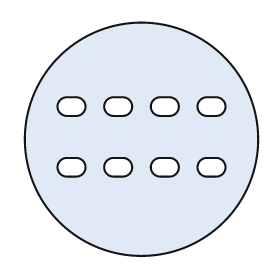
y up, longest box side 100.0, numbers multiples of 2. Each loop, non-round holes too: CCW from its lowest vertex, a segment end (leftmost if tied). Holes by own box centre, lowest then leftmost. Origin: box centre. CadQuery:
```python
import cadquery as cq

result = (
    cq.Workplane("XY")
    .moveTo(0.0, 0.0)
    .circle(50.0)
    .moveTo(-32.0, -16.0)
    .lineTo(-28.0, -16.0)
    .threePointArc((-24.0, -12.0), (-28.0, -8.0))
    .lineTo(-32.0, -8.0)
    .threePointArc((-36.0, -12.0), (-32.0, -16.0))
    .close()
    .moveTo(-12.0, -16.0)
    .lineTo(-8.0, -16.0)
    .threePointArc((-4.0, -12.0), (-8.0, -8.0))
    .lineTo(-12.0, -8.0)
    .threePointArc((-16.0, -12.0), (-12.0, -16.0))
    .close()
    .moveTo(8.0, -16.0)
    .lineTo(12.0, -16.0)
    .threePointArc((16.0, -12.0), (12.0, -8.0))
    .lineTo(8.0, -8.0)
    .threePointArc((4.0, -12.0), (8.0, -16.0))
    .close()
    .moveTo(28.0, -16.0)
    .lineTo(32.0, -16.0)
    .threePointArc((36.0, -12.0), (32.0, -8.0))
    .lineTo(28.0, -8.0)
    .threePointArc((24.0, -12.0), (28.0, -16.0))
    .close()
    .moveTo(-32.0, 10.0)
    .lineTo(-28.0, 10.0)
    .threePointArc((-24.0, 14.0), (-28.0, 18.0))
    .lineTo(-32.0, 18.0)
    .threePointArc((-36.0, 14.0), (-32.0, 10.0))
    .close()
    .moveTo(-12.0, 10.0)
    .lineTo(-8.0, 10.0)
    .threePointArc((-4.0, 14.0), (-8.0, 18.0))
    .lineTo(-12.0, 18.0)
    .threePointArc((-16.0, 14.0), (-12.0, 10.0))
    .close()
    .moveTo(8.0, 10.0)
    .lineTo(12.0, 10.0)
    .threePointArc((16.0, 14.0), (12.0, 18.0))
    .lineTo(8.0, 18.0)
    .threePointArc((4.0, 14.0), (8.0, 10.0))
    .close()
    .moveTo(28.0, 10.0)
    .lineTo(32.0, 10.0)
    .threePointArc((36.0, 14.0), (32.0, 18.0))
    .lineTo(28.0, 18.0)
    .threePointArc((24.0, 14.0), (28.0, 10.0))
    .close()
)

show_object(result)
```